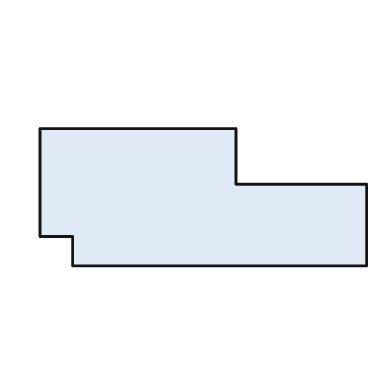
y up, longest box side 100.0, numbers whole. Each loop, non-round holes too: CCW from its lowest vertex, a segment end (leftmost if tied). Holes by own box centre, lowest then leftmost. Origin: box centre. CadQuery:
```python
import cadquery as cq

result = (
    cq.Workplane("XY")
    .moveTo(-40.0, -21.0)
    .lineTo(50.0, -21.0)
    .lineTo(50.0, 4.0)
    .lineTo(10.0, 4.0)
    .lineTo(10.0, 21.0)
    .lineTo(-50.0, 21.0)
    .lineTo(-50.0, -12.0)
    .lineTo(-40.0, -12.0)
    .close()
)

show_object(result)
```